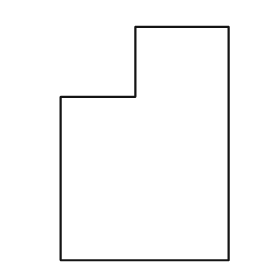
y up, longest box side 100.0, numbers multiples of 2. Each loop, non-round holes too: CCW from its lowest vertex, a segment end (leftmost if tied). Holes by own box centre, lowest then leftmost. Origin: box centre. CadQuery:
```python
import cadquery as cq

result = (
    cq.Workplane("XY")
    .moveTo(-36.0, -50.0)
    .lineTo(36.0, -50.0)
    .lineTo(36.0, 50.0)
    .lineTo(-4.0, 50.0)
    .lineTo(-4.0, 20.0)
    .lineTo(-36.0, 20.0)
    .close()
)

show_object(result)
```